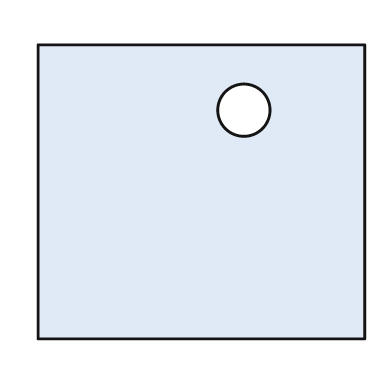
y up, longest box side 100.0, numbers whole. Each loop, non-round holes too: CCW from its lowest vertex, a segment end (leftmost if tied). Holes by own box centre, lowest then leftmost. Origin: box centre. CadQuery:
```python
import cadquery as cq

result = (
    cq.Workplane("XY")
    .moveTo(-50.0, -45.0)
    .lineTo(50.0, -45.0)
    .lineTo(50.0, 45.0)
    .lineTo(-50.0, 45.0)
    .close()
    .moveTo(13.0, 25.0)
    .circle(8.0)
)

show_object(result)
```